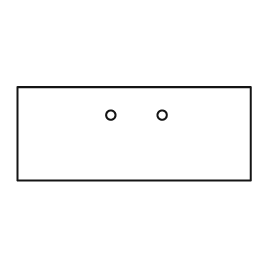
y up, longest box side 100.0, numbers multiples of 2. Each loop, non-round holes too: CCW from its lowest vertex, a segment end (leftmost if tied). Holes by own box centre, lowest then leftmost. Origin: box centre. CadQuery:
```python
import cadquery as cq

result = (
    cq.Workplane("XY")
    .moveTo(-50.0, -20.0)
    .lineTo(50.0, -20.0)
    .lineTo(50.0, 20.0)
    .lineTo(-50.0, 20.0)
    .close()
    .moveTo(-10.0, 8.0)
    .circle(2.0)
    .moveTo(12.0, 8.0)
    .circle(2.0)
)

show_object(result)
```